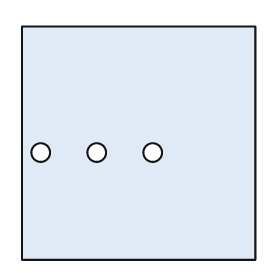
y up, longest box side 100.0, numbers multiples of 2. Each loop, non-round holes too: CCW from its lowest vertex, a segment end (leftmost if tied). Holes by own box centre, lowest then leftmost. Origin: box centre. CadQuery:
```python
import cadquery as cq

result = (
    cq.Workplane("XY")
    .moveTo(-50.0, -50.0)
    .lineTo(50.0, -50.0)
    .lineTo(50.0, 50.0)
    .lineTo(-50.0, 50.0)
    .close()
    .moveTo(-42.0, -4.0)
    .circle(4.0)
    .moveTo(-18.0, -4.0)
    .circle(4.0)
    .moveTo(6.0, -4.0)
    .circle(4.0)
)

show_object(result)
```